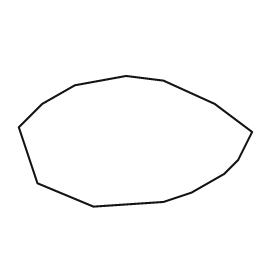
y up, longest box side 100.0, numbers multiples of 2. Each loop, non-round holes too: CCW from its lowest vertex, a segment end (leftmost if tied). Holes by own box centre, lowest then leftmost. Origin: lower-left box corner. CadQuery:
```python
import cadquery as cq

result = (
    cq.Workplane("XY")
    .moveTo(32.0, 0.0)
    .lineTo(62.0, 2.0)
    .lineTo(74.0, 6.0)
    .lineTo(88.0, 14.0)
    .lineTo(94.0, 20.0)
    .lineTo(100.0, 32.0)
    .lineTo(84.0, 44.0)
    .lineTo(62.0, 54.0)
    .lineTo(46.0, 56.0)
    .lineTo(24.0, 52.0)
    .lineTo(10.0, 44.0)
    .lineTo(0.0, 34.0)
    .lineTo(8.0, 10.0)
    .close()
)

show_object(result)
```